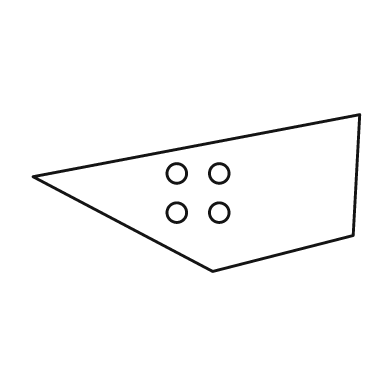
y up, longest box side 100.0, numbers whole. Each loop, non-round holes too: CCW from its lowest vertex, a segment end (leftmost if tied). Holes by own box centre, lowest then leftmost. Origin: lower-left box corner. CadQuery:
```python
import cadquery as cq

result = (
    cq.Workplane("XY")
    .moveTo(55.0, 0.0)
    .lineTo(98.0, 11.0)
    .lineTo(100.0, 48.0)
    .lineTo(0.0, 29.0)
    .close()
    .moveTo(44.0, 18.0)
    .circle(3.0)
    .moveTo(57.0, 18.0)
    .circle(3.0)
    .moveTo(44.0, 30.0)
    .circle(3.0)
    .moveTo(57.0, 30.0)
    .circle(3.0)
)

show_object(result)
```